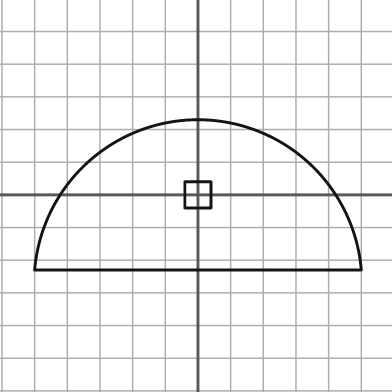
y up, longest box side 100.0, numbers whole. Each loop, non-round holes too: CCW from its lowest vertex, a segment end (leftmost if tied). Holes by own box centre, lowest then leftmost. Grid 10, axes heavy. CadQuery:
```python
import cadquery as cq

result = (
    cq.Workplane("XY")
    .moveTo(-50.0, -23.0)
    .lineTo(50.0, -23.0)
    .threePointArc((0.0, 23.0), (-50.0, -23.0))
    .close()
    .moveTo(-4.0, -4.0)
    .lineTo(4.0, -4.0)
    .lineTo(4.0, 4.0)
    .lineTo(-4.0, 4.0)
    .close()
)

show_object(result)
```